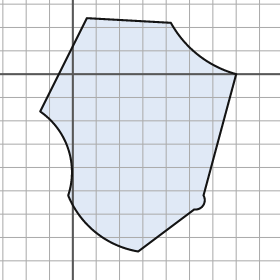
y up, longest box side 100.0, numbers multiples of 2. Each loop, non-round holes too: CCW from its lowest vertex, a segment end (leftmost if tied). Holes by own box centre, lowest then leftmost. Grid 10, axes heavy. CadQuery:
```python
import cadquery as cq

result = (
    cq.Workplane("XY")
    .moveTo(28.0, -76.0)
    .lineTo(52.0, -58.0)
    .threePointArc((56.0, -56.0), (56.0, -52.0))
    .lineTo(70.0, 0.0)
    .threePointArc((54.0, 8.0), (42.0, 22.0))
    .lineTo(6.0, 24.0)
    .lineTo(-14.0, -16.0)
    .threePointArc((-2.0, -32.0), (-2.0, -52.0))
    .threePointArc((10.0, -68.0), (28.0, -76.0))
    .close()
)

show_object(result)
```